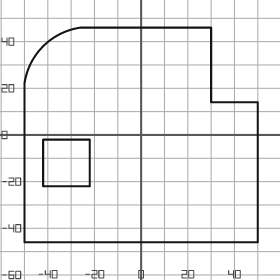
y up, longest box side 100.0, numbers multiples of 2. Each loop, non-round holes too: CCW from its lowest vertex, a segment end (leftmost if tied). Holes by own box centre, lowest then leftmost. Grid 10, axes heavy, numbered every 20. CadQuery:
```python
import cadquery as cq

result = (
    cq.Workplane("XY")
    .moveTo(-50.0, -46.0)
    .lineTo(50.0, -46.0)
    .lineTo(50.0, 14.0)
    .lineTo(30.0, 14.0)
    .lineTo(30.0, 46.0)
    .lineTo(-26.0, 46.0)
    .threePointArc((-42.0, 38.0), (-50.0, 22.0))
    .close()
    .moveTo(-42.0, -22.0)
    .lineTo(-22.0, -22.0)
    .lineTo(-22.0, -2.0)
    .lineTo(-42.0, -2.0)
    .close()
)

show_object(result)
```